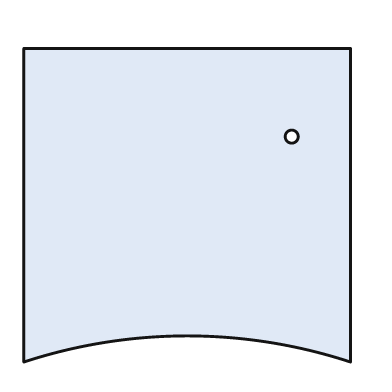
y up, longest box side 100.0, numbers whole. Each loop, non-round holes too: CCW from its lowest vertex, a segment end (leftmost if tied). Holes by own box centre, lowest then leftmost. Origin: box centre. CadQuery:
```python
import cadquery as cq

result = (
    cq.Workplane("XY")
    .moveTo(-50.0, -48.0)
    .threePointArc((0.0, -40.0), (50.0, -48.0))
    .lineTo(50.0, 48.0)
    .lineTo(-50.0, 48.0)
    .close()
    .moveTo(32.0, 21.0)
    .circle(2.0)
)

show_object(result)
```